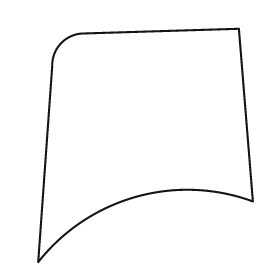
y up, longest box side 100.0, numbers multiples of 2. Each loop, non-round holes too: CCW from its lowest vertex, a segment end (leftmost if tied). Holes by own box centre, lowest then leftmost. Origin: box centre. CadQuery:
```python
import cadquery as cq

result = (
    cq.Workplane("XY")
    .moveTo(-46.0, -50.0)
    .threePointArc((-4.0, -22.0), (46.0, -24.0))
    .lineTo(40.0, 50.0)
    .lineTo(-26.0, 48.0)
    .threePointArc((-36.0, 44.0), (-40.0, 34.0))
    .close()
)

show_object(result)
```